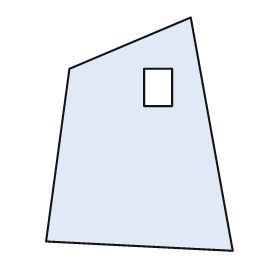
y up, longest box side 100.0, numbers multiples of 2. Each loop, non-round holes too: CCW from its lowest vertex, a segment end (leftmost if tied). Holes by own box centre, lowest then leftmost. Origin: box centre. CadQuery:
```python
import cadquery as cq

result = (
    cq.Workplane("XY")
    .moveTo(40.0, -50.0)
    .lineTo(22.0, 50.0)
    .lineTo(-30.0, 28.0)
    .lineTo(-40.0, -46.0)
    .close()
    .moveTo(2.0, 12.0)
    .lineTo(14.0, 12.0)
    .lineTo(14.0, 28.0)
    .lineTo(2.0, 28.0)
    .close()
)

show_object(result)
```